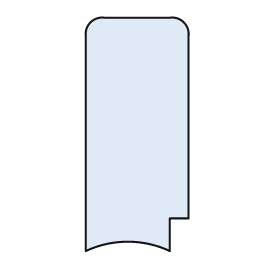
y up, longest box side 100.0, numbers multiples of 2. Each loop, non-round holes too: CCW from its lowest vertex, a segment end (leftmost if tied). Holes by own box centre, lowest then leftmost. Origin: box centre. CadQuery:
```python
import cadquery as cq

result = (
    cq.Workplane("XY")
    .moveTo(-22.0, -50.0)
    .threePointArc((-4.0, -46.0), (14.0, -50.0))
    .lineTo(14.0, -36.0)
    .lineTo(22.0, -36.0)
    .lineTo(22.0, 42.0)
    .threePointArc((20.0, 48.0), (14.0, 50.0))
    .lineTo(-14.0, 50.0)
    .threePointArc((-20.0, 48.0), (-22.0, 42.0))
    .close()
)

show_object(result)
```